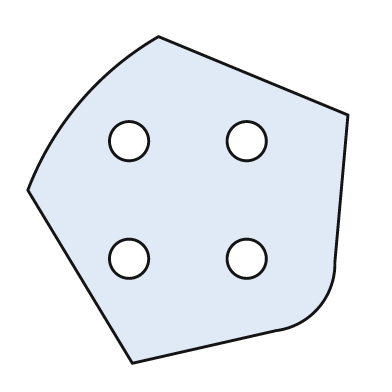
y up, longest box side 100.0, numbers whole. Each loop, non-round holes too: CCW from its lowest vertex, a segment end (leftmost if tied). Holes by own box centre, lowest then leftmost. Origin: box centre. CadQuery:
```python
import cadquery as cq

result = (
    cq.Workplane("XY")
    .moveTo(-17.0, -50.0)
    .lineTo(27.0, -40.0)
    .threePointArc((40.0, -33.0), (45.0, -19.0))
    .lineTo(49.0, 26.0)
    .lineTo(-9.0, 50.0)
    .threePointArc((-33.0, 30.0), (-49.0, 3.0))
    .close()
    .moveTo(-18.0, -18.0)
    .circle(6.0)
    .moveTo(18.0, -18.0)
    .circle(6.0)
    .moveTo(-18.0, 18.0)
    .circle(6.0)
    .moveTo(18.0, 18.0)
    .circle(6.0)
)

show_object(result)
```